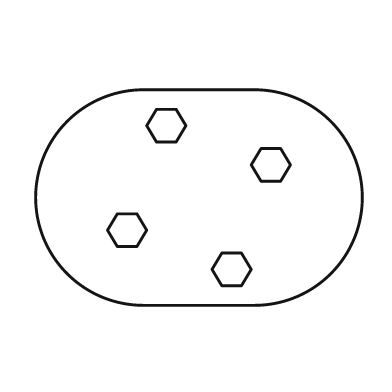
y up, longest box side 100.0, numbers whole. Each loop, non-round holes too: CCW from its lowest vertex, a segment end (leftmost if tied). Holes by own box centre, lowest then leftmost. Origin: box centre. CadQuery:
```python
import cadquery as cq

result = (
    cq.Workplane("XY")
    .moveTo(-17.0, -33.0)
    .lineTo(17.0, -33.0)
    .threePointArc((50.0, 0.0), (17.0, 33.0))
    .lineTo(-17.0, 33.0)
    .threePointArc((-50.0, 0.0), (-17.0, -33.0))
    .close()
    .moveTo(7.0, -27.0)
    .lineTo(13.0, -27.0)
    .lineTo(16.0, -22.0)
    .lineTo(13.0, -17.0)
    .lineTo(7.0, -17.0)
    .lineTo(4.0, -22.0)
    .close()
    .moveTo(-25.0, -15.0)
    .lineTo(-19.0, -15.0)
    .lineTo(-16.0, -10.0)
    .lineTo(-19.0, -5.0)
    .lineTo(-25.0, -5.0)
    .lineTo(-28.0, -10.0)
    .close()
    .moveTo(19.0, 5.0)
    .lineTo(25.0, 5.0)
    .lineTo(28.0, 10.0)
    .lineTo(25.0, 15.0)
    .lineTo(19.0, 15.0)
    .lineTo(16.0, 10.0)
    .close()
    .moveTo(-13.0, 17.0)
    .lineTo(-7.0, 17.0)
    .lineTo(-4.0, 22.0)
    .lineTo(-7.0, 27.0)
    .lineTo(-13.0, 27.0)
    .lineTo(-16.0, 22.0)
    .close()
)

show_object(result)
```